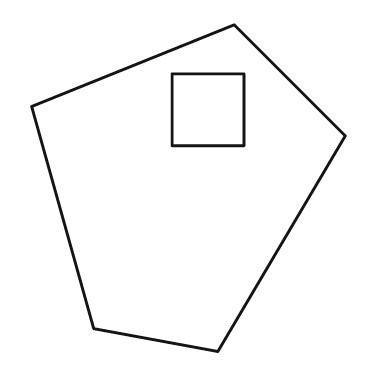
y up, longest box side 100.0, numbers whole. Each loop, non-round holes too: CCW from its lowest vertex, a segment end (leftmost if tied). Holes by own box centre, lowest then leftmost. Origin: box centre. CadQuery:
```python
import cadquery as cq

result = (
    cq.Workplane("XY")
    .moveTo(9.0, -50.0)
    .lineTo(48.0, 16.0)
    .lineTo(14.0, 50.0)
    .lineTo(-48.0, 25.0)
    .lineTo(-29.0, -43.0)
    .close()
    .moveTo(-5.0, 13.0)
    .lineTo(17.0, 13.0)
    .lineTo(17.0, 35.0)
    .lineTo(-5.0, 35.0)
    .close()
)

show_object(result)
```